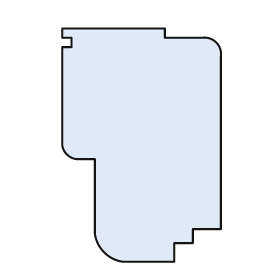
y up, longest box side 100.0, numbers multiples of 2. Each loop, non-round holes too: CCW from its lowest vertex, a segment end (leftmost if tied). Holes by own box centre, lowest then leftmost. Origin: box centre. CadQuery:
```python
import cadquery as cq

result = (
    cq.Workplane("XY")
    .moveTo(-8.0, -50.0)
    .lineTo(14.0, -50.0)
    .lineTo(14.0, -42.0)
    .lineTo(22.0, -42.0)
    .lineTo(22.0, -36.0)
    .lineTo(34.0, -36.0)
    .lineTo(34.0, 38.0)
    .threePointArc((32.0, 44.0), (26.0, 46.0))
    .lineTo(10.0, 46.0)
    .lineTo(10.0, 50.0)
    .lineTo(-34.0, 50.0)
    .lineTo(-34.0, 46.0)
    .lineTo(-30.0, 46.0)
    .lineTo(-30.0, 42.0)
    .lineTo(-34.0, 42.0)
    .lineTo(-34.0, 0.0)
    .threePointArc((-32.0, -4.0), (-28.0, -6.0))
    .lineTo(-20.0, -6.0)
    .lineTo(-20.0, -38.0)
    .threePointArc((-16.0, -46.0), (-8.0, -50.0))
    .close()
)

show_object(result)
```